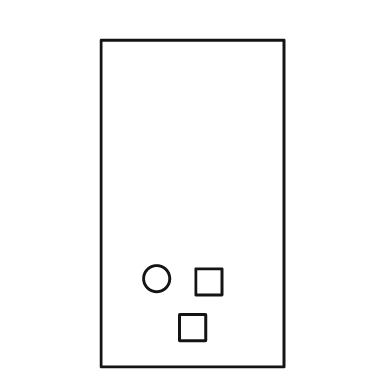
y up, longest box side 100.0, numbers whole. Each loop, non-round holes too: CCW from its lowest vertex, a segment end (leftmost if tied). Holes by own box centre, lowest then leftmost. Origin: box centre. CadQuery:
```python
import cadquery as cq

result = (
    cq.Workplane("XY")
    .moveTo(-28.0, -50.0)
    .lineTo(28.0, -50.0)
    .lineTo(28.0, 50.0)
    .lineTo(-28.0, 50.0)
    .close()
    .moveTo(-4.0, -42.0)
    .lineTo(4.0, -42.0)
    .lineTo(4.0, -34.0)
    .lineTo(-4.0, -34.0)
    .close()
    .moveTo(1.0, -28.0)
    .lineTo(9.0, -28.0)
    .lineTo(9.0, -20.0)
    .lineTo(1.0, -20.0)
    .close()
    .moveTo(-11.0, -23.0)
    .circle(4.0)
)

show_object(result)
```